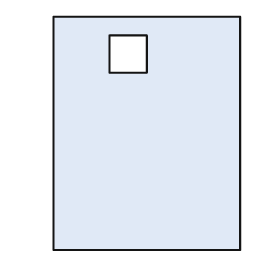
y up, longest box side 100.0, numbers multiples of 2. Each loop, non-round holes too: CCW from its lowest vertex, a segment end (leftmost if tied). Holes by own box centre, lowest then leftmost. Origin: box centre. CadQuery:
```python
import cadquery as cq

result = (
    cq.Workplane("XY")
    .moveTo(-40.0, -50.0)
    .lineTo(40.0, -50.0)
    .lineTo(40.0, 50.0)
    .lineTo(-40.0, 50.0)
    .close()
    .moveTo(-16.0, 26.0)
    .lineTo(0.0, 26.0)
    .lineTo(0.0, 42.0)
    .lineTo(-16.0, 42.0)
    .close()
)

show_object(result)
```